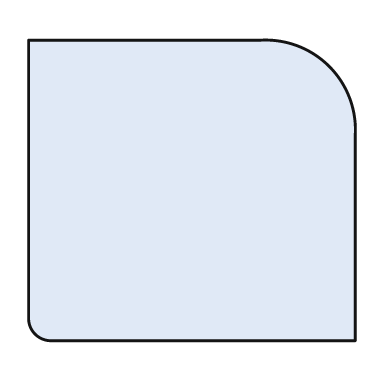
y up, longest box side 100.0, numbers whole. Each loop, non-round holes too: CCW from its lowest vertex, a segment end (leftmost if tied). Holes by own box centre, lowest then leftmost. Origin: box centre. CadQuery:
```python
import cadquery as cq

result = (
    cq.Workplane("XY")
    .moveTo(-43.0, -46.0)
    .lineTo(50.0, -46.0)
    .lineTo(50.0, 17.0)
    .threePointArc((42.0, 38.0), (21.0, 46.0))
    .lineTo(-50.0, 46.0)
    .lineTo(-50.0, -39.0)
    .threePointArc((-48.0, -44.0), (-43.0, -46.0))
    .close()
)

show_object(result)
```